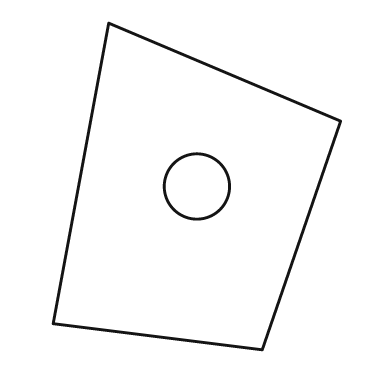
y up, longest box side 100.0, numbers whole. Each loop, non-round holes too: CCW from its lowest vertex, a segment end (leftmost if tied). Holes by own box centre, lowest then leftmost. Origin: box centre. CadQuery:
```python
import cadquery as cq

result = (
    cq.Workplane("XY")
    .moveTo(20.0, -50.0)
    .lineTo(44.0, 20.0)
    .lineTo(-27.0, 50.0)
    .lineTo(-44.0, -42.0)
    .close()
    .moveTo(0.0, 0.0)
    .circle(10.0)
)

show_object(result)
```